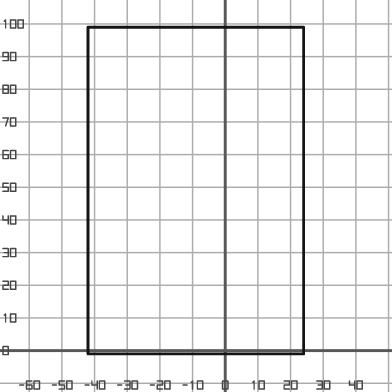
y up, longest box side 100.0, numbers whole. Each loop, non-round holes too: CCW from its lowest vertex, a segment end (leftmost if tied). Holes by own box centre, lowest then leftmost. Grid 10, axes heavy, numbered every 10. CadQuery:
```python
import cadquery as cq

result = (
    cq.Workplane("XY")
    .moveTo(-42.0, -1.0)
    .lineTo(24.0, -1.0)
    .lineTo(24.0, 99.0)
    .lineTo(-42.0, 99.0)
    .close()
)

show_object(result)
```